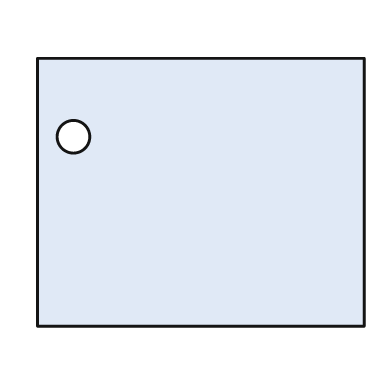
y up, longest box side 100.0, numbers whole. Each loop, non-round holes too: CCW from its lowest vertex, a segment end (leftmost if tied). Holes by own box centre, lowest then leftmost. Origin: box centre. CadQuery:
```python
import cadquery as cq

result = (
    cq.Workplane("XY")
    .moveTo(-50.0, -41.0)
    .lineTo(50.0, -41.0)
    .lineTo(50.0, 41.0)
    .lineTo(-50.0, 41.0)
    .close()
    .moveTo(-39.0, 17.0)
    .circle(5.0)
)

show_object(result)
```